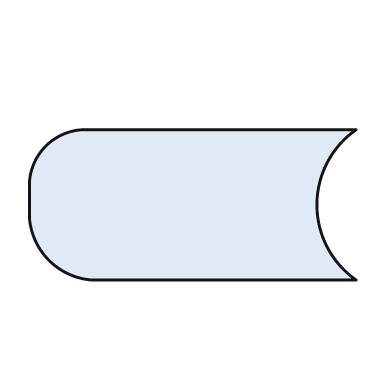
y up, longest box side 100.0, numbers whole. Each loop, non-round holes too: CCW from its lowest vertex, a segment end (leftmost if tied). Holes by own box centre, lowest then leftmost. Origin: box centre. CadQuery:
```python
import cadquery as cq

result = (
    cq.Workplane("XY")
    .moveTo(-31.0, -23.0)
    .lineTo(50.0, -23.0)
    .threePointArc((38.0, 0.0), (50.0, 23.0))
    .lineTo(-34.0, 23.0)
    .threePointArc((-45.0, 18.0), (-50.0, 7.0))
    .lineTo(-50.0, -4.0)
    .threePointArc((-44.0, -17.0), (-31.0, -23.0))
    .close()
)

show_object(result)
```